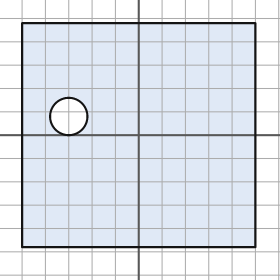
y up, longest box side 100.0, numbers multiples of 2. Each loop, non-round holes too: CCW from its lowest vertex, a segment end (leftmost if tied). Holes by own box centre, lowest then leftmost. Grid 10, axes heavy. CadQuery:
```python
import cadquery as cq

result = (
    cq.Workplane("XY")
    .moveTo(-50.0, -48.0)
    .lineTo(50.0, -48.0)
    .lineTo(50.0, 48.0)
    .lineTo(-50.0, 48.0)
    .close()
    .moveTo(-30.0, 8.0)
    .circle(8.0)
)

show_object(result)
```